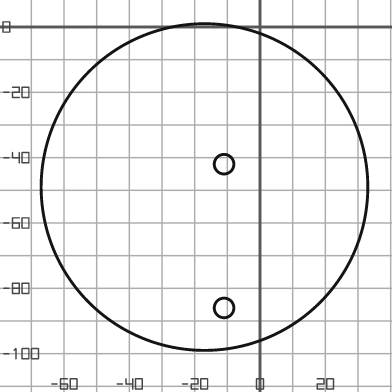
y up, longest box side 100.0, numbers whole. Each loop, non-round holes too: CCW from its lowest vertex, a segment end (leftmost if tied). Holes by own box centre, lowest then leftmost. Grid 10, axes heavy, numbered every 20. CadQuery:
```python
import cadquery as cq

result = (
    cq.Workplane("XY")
    .moveTo(-17.0, -49.0)
    .circle(50.0)
    .moveTo(-11.0, -86.0)
    .circle(3.0)
    .moveTo(-11.0, -42.0)
    .circle(3.0)
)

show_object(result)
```